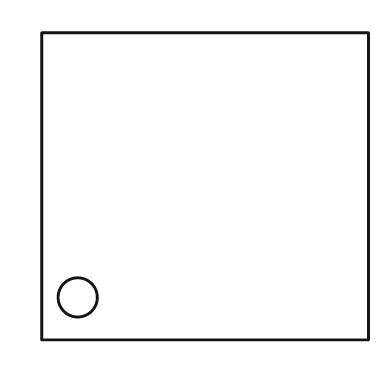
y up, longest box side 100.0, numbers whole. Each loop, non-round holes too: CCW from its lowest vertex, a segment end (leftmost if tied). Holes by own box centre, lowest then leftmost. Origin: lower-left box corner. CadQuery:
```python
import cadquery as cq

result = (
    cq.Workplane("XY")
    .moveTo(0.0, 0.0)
    .lineTo(100.0, 0.0)
    .lineTo(100.0, 94.0)
    .lineTo(0.0, 94.0)
    .close()
    .moveTo(11.0, 13.0)
    .circle(6.0)
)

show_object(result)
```